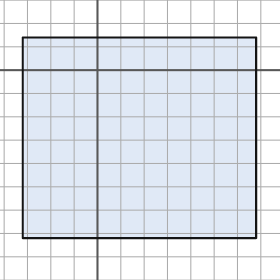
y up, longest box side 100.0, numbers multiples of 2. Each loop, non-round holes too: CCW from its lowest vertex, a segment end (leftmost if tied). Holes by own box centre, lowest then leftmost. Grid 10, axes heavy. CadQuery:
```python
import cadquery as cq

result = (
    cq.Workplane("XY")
    .moveTo(-32.0, -72.0)
    .lineTo(68.0, -72.0)
    .lineTo(68.0, 14.0)
    .lineTo(-32.0, 14.0)
    .close()
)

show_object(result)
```